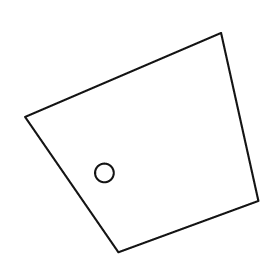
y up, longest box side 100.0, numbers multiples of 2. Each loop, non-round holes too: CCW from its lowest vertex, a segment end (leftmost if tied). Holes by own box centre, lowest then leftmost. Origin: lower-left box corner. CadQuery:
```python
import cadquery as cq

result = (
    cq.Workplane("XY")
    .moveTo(40.0, 0.0)
    .lineTo(100.0, 22.0)
    .lineTo(84.0, 94.0)
    .lineTo(0.0, 58.0)
    .close()
    .moveTo(34.0, 34.0)
    .circle(4.0)
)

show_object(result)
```